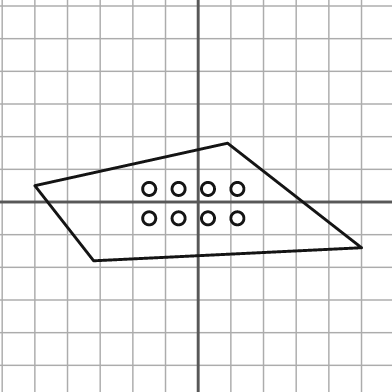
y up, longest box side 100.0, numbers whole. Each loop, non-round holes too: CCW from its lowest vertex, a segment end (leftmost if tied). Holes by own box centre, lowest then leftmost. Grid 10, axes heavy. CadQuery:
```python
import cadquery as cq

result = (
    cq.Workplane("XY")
    .moveTo(-32.0, -18.0)
    .lineTo(50.0, -14.0)
    .lineTo(9.0, 18.0)
    .lineTo(-50.0, 5.0)
    .close()
    .moveTo(-15.0, -5.0)
    .circle(2.0)
    .moveTo(-6.0, -5.0)
    .circle(2.0)
    .moveTo(3.0, -5.0)
    .circle(2.0)
    .moveTo(12.0, -5.0)
    .circle(2.0)
    .moveTo(-15.0, 4.0)
    .circle(2.0)
    .moveTo(-6.0, 4.0)
    .circle(2.0)
    .moveTo(3.0, 4.0)
    .circle(2.0)
    .moveTo(12.0, 4.0)
    .circle(2.0)
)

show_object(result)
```